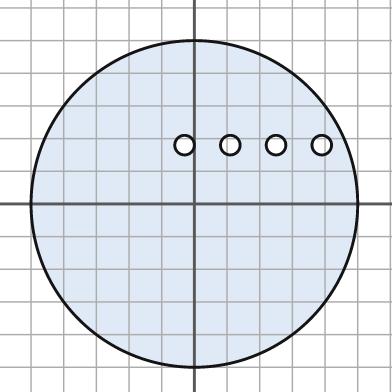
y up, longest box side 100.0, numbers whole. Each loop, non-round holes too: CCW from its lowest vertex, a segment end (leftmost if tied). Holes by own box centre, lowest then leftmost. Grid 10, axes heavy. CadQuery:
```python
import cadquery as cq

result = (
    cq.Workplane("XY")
    .moveTo(0.0, 0.0)
    .circle(50.0)
    .moveTo(-3.0, 18.0)
    .circle(3.0)
    .moveTo(11.0, 18.0)
    .circle(3.0)
    .moveTo(25.0, 18.0)
    .circle(3.0)
    .moveTo(39.0, 18.0)
    .circle(3.0)
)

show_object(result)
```